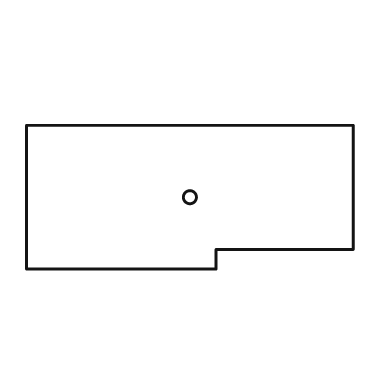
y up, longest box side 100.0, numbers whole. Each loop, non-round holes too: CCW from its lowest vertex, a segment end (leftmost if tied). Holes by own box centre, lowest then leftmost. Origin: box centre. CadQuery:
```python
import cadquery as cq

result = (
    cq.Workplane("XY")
    .moveTo(-50.0, -22.0)
    .lineTo(8.0, -22.0)
    .lineTo(8.0, -16.0)
    .lineTo(50.0, -16.0)
    .lineTo(50.0, 22.0)
    .lineTo(-50.0, 22.0)
    .close()
    .moveTo(0.0, 0.0)
    .circle(2.0)
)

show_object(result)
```